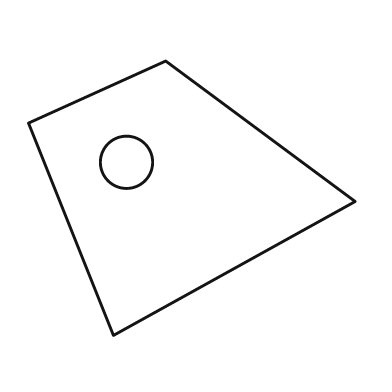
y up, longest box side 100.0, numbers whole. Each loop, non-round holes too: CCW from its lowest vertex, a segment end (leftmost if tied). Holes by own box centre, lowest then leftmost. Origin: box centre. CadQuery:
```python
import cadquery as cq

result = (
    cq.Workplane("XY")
    .moveTo(-24.0, -42.0)
    .lineTo(50.0, -1.0)
    .lineTo(-8.0, 42.0)
    .lineTo(-50.0, 23.0)
    .close()
    .moveTo(-20.0, 11.0)
    .circle(8.0)
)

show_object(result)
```